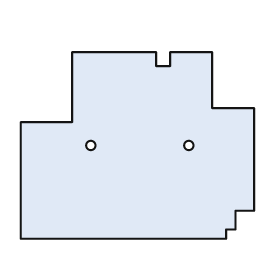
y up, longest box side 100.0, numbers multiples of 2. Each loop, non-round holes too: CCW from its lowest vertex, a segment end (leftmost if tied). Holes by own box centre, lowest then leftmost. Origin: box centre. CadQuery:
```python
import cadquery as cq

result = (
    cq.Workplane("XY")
    .moveTo(-50.0, -40.0)
    .lineTo(38.0, -40.0)
    .lineTo(38.0, -36.0)
    .lineTo(42.0, -36.0)
    .lineTo(42.0, -28.0)
    .lineTo(50.0, -28.0)
    .lineTo(50.0, 16.0)
    .lineTo(32.0, 16.0)
    .lineTo(32.0, 40.0)
    .lineTo(14.0, 40.0)
    .lineTo(14.0, 34.0)
    .lineTo(8.0, 34.0)
    .lineTo(8.0, 40.0)
    .lineTo(-28.0, 40.0)
    .lineTo(-28.0, 10.0)
    .lineTo(-50.0, 10.0)
    .close()
    .moveTo(-20.0, 0.0)
    .circle(2.0)
    .moveTo(22.0, 0.0)
    .circle(2.0)
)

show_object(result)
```